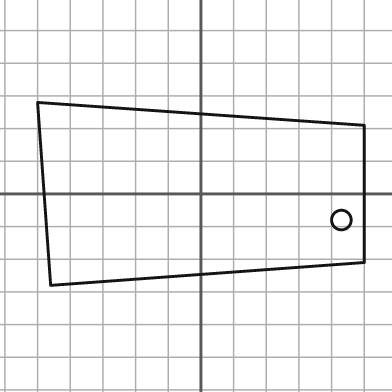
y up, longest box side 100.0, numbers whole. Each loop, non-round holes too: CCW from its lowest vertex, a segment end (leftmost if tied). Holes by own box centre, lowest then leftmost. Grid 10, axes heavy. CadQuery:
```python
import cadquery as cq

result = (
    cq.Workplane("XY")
    .moveTo(-46.0, -28.0)
    .lineTo(50.0, -21.0)
    .lineTo(50.0, 21.0)
    .lineTo(-50.0, 28.0)
    .close()
    .moveTo(43.0, -8.0)
    .circle(3.0)
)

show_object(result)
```